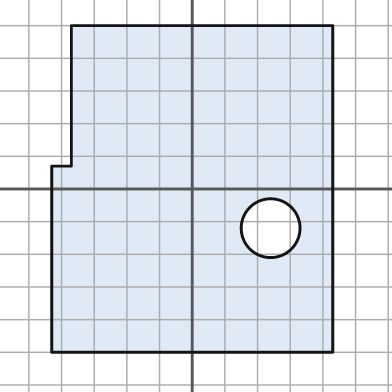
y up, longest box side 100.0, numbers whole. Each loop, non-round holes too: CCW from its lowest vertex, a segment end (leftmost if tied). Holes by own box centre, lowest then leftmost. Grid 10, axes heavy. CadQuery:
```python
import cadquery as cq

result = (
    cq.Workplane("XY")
    .moveTo(-43.0, -50.0)
    .lineTo(43.0, -50.0)
    .lineTo(43.0, 50.0)
    .lineTo(-37.0, 50.0)
    .lineTo(-37.0, 7.0)
    .lineTo(-43.0, 7.0)
    .close()
    .moveTo(24.0, -12.0)
    .circle(9.0)
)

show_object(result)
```